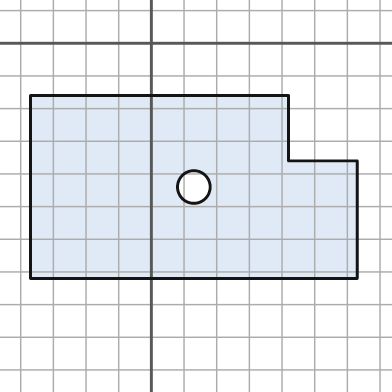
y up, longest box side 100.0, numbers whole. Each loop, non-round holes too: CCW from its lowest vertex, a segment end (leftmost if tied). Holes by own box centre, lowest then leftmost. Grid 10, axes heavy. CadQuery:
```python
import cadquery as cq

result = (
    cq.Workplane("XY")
    .moveTo(-37.0, -72.0)
    .lineTo(63.0, -72.0)
    .lineTo(63.0, -36.0)
    .lineTo(42.0, -36.0)
    .lineTo(42.0, -16.0)
    .lineTo(-37.0, -16.0)
    .close()
    .moveTo(13.0, -44.0)
    .circle(5.0)
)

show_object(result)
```